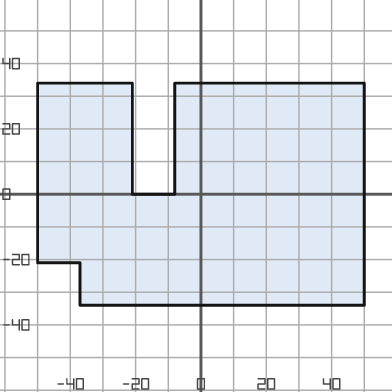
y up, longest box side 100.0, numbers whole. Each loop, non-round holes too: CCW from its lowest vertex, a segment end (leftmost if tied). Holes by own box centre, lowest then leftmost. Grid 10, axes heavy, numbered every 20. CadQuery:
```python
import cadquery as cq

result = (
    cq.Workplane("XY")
    .moveTo(-37.0, -34.0)
    .lineTo(50.0, -34.0)
    .lineTo(50.0, 34.0)
    .lineTo(-8.0, 34.0)
    .lineTo(-8.0, 0.0)
    .lineTo(-21.0, 0.0)
    .lineTo(-21.0, 34.0)
    .lineTo(-50.0, 34.0)
    .lineTo(-50.0, -21.0)
    .lineTo(-37.0, -21.0)
    .close()
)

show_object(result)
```